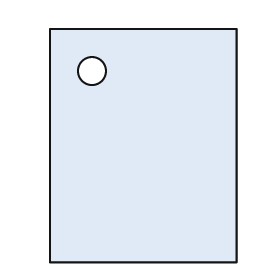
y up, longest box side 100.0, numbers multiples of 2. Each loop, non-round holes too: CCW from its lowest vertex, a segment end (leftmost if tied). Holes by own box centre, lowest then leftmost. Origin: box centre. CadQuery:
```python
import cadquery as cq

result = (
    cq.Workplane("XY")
    .moveTo(-40.0, -50.0)
    .lineTo(40.0, -50.0)
    .lineTo(40.0, 50.0)
    .lineTo(-40.0, 50.0)
    .close()
    .moveTo(-22.0, 32.0)
    .circle(6.0)
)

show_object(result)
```